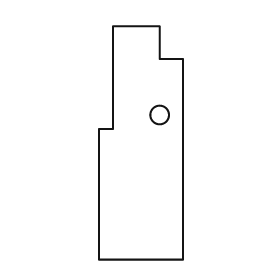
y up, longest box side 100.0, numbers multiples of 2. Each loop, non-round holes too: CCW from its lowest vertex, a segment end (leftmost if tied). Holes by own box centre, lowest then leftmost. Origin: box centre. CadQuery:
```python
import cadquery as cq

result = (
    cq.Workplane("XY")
    .moveTo(-18.0, -50.0)
    .lineTo(18.0, -50.0)
    .lineTo(18.0, 36.0)
    .lineTo(8.0, 36.0)
    .lineTo(8.0, 50.0)
    .lineTo(-12.0, 50.0)
    .lineTo(-12.0, 6.0)
    .lineTo(-18.0, 6.0)
    .close()
    .moveTo(8.0, 12.0)
    .circle(4.0)
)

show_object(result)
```